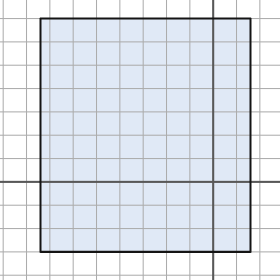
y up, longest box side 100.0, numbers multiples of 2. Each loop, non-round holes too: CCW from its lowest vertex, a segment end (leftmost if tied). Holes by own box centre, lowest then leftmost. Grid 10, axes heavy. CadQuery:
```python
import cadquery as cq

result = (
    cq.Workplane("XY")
    .moveTo(-74.0, -30.0)
    .lineTo(16.0, -30.0)
    .lineTo(16.0, 70.0)
    .lineTo(-74.0, 70.0)
    .close()
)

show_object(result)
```